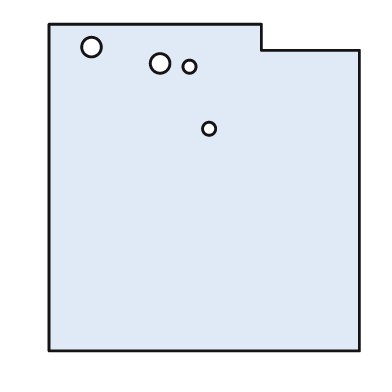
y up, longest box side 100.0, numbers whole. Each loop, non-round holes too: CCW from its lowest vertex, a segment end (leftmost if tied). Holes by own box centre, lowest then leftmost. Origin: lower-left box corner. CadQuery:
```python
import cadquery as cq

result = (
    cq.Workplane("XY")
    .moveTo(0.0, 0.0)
    .lineTo(95.0, 0.0)
    .lineTo(95.0, 92.0)
    .lineTo(65.0, 92.0)
    .lineTo(65.0, 100.0)
    .lineTo(0.0, 100.0)
    .close()
    .moveTo(49.0, 68.0)
    .circle(2.0)
    .moveTo(43.0, 87.0)
    .circle(2.0)
    .moveTo(34.0, 88.0)
    .circle(3.0)
    .moveTo(13.0, 93.0)
    .circle(3.0)
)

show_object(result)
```